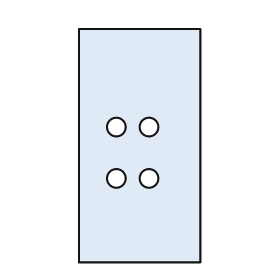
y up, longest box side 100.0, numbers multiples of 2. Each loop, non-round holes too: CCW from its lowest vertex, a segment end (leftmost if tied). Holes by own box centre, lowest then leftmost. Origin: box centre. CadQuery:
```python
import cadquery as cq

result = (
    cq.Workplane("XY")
    .moveTo(-26.0, -50.0)
    .lineTo(26.0, -50.0)
    .lineTo(26.0, 50.0)
    .lineTo(-26.0, 50.0)
    .close()
    .moveTo(-10.0, -14.0)
    .circle(4.0)
    .moveTo(4.0, -14.0)
    .circle(4.0)
    .moveTo(-10.0, 8.0)
    .circle(4.0)
    .moveTo(4.0, 8.0)
    .circle(4.0)
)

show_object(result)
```